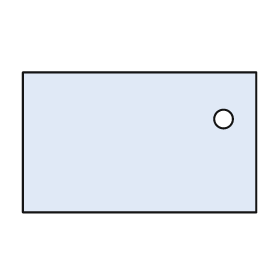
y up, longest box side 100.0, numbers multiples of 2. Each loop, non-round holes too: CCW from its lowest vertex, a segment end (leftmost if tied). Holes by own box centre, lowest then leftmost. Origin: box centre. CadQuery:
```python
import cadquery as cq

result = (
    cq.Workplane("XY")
    .moveTo(-50.0, -30.0)
    .lineTo(50.0, -30.0)
    .lineTo(50.0, 30.0)
    .lineTo(-50.0, 30.0)
    .close()
    .moveTo(36.0, 10.0)
    .circle(4.0)
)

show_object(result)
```